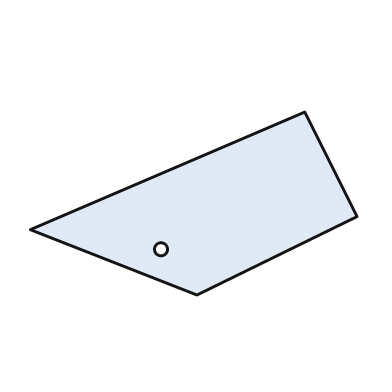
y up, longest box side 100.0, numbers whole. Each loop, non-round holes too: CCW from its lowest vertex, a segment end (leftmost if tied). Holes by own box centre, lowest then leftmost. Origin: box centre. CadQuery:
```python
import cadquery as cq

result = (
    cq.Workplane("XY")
    .moveTo(1.0, -28.0)
    .lineTo(50.0, -4.0)
    .lineTo(34.0, 28.0)
    .lineTo(-50.0, -8.0)
    .close()
    .moveTo(-10.0, -14.0)
    .circle(2.0)
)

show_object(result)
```